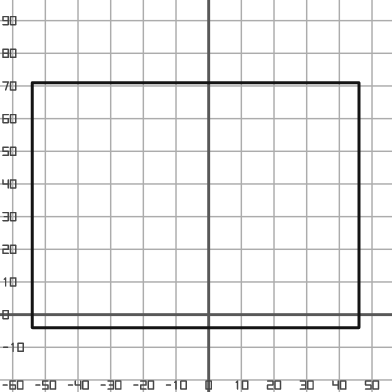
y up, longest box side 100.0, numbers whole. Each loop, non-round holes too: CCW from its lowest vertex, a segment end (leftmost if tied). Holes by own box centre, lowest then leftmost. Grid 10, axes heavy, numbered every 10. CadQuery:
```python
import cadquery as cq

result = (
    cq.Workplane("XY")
    .moveTo(-54.0, -4.0)
    .lineTo(46.0, -4.0)
    .lineTo(46.0, 71.0)
    .lineTo(-54.0, 71.0)
    .close()
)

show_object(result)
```